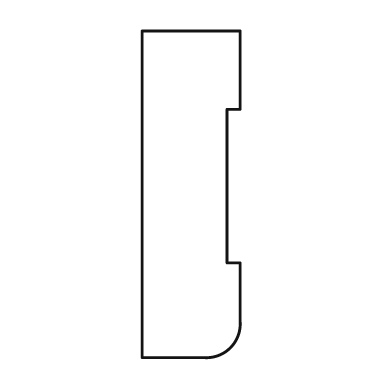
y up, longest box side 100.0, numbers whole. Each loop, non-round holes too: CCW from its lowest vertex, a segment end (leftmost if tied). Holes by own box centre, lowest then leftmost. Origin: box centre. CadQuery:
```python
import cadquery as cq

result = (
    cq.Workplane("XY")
    .moveTo(-15.0, -50.0)
    .lineTo(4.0, -50.0)
    .threePointArc((12.0, -47.0), (15.0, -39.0))
    .lineTo(15.0, -21.0)
    .lineTo(11.0, -21.0)
    .lineTo(11.0, 26.0)
    .lineTo(15.0, 26.0)
    .lineTo(15.0, 50.0)
    .lineTo(-15.0, 50.0)
    .close()
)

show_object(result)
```